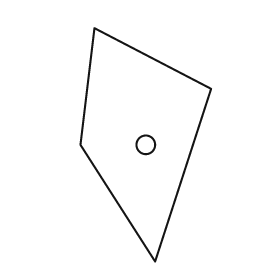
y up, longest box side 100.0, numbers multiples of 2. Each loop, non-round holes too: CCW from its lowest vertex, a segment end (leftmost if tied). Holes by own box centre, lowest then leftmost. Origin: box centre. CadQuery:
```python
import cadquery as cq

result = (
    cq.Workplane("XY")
    .moveTo(4.0, -50.0)
    .lineTo(28.0, 24.0)
    .lineTo(-22.0, 50.0)
    .lineTo(-28.0, 0.0)
    .close()
    .moveTo(0.0, 0.0)
    .circle(4.0)
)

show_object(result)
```